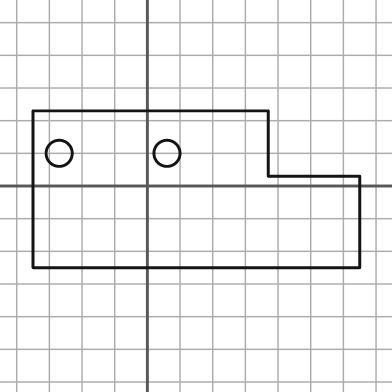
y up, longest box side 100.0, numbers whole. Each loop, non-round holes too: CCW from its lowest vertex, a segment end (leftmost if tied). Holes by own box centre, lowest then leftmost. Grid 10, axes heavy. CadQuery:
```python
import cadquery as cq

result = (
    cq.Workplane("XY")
    .moveTo(-35.0, -25.0)
    .lineTo(65.0, -25.0)
    .lineTo(65.0, 3.0)
    .lineTo(37.0, 3.0)
    .lineTo(37.0, 23.0)
    .lineTo(-35.0, 23.0)
    .close()
    .moveTo(-27.0, 10.0)
    .circle(4.0)
    .moveTo(6.0, 10.0)
    .circle(4.0)
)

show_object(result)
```